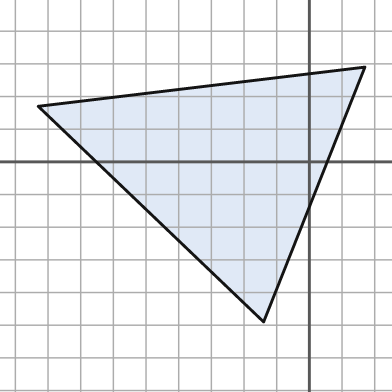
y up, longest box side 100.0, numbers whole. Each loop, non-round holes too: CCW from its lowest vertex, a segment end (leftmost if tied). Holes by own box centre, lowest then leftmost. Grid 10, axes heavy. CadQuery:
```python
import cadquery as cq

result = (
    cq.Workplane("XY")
    .moveTo(-14.0, -49.0)
    .lineTo(17.0, 29.0)
    .lineTo(-83.0, 17.0)
    .close()
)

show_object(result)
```